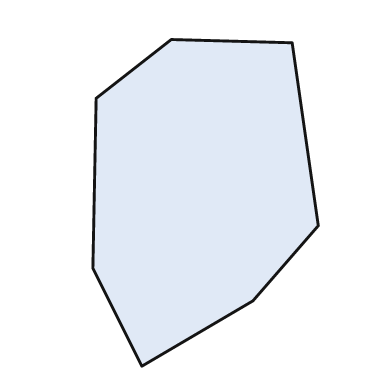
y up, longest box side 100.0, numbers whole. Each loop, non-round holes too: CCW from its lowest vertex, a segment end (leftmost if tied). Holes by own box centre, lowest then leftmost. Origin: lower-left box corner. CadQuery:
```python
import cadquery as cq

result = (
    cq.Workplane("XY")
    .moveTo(15.0, 0.0)
    .lineTo(49.0, 20.0)
    .lineTo(69.0, 43.0)
    .lineTo(61.0, 99.0)
    .lineTo(24.0, 100.0)
    .lineTo(1.0, 82.0)
    .lineTo(0.0, 30.0)
    .close()
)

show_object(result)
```